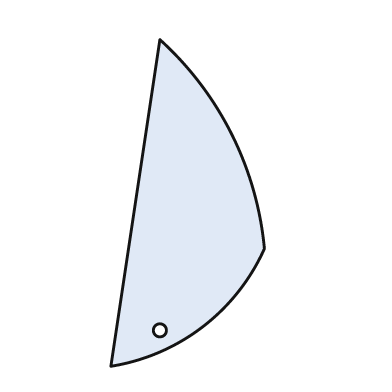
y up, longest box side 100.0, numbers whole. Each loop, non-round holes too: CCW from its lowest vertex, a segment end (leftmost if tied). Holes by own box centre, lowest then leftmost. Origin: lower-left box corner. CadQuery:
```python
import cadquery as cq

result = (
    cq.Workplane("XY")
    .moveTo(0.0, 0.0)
    .threePointArc((28.0, 12.0), (47.0, 36.0))
    .threePointArc((37.0, 71.0), (15.0, 100.0))
    .close()
    .moveTo(15.0, 11.0)
    .circle(2.0)
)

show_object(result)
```